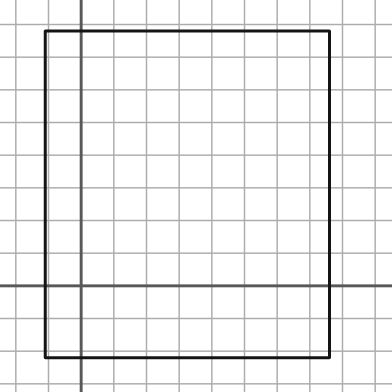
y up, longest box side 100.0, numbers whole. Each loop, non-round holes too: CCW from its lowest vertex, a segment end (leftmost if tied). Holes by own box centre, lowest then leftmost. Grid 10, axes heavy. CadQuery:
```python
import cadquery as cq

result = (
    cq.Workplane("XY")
    .moveTo(-11.0, -22.0)
    .lineTo(76.0, -22.0)
    .lineTo(76.0, 78.0)
    .lineTo(-11.0, 78.0)
    .close()
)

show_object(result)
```